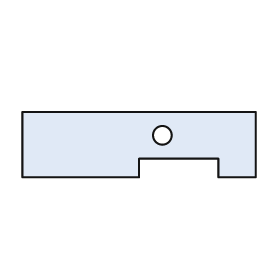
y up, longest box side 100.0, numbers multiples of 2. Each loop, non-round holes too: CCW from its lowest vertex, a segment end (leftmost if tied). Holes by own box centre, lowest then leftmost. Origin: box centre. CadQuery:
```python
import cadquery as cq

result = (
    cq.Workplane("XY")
    .moveTo(-50.0, -14.0)
    .lineTo(0.0, -14.0)
    .lineTo(0.0, -6.0)
    .lineTo(34.0, -6.0)
    .lineTo(34.0, -14.0)
    .lineTo(50.0, -14.0)
    .lineTo(50.0, 14.0)
    .lineTo(-50.0, 14.0)
    .close()
    .moveTo(10.0, 4.0)
    .circle(4.0)
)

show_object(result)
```